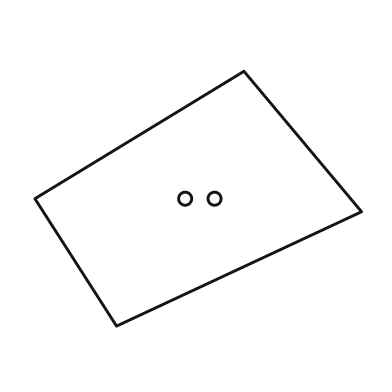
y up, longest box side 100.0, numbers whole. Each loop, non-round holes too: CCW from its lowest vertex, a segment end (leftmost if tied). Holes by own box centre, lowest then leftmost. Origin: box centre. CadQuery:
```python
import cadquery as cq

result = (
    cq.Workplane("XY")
    .moveTo(-25.0, -39.0)
    .lineTo(50.0, -4.0)
    .lineTo(14.0, 39.0)
    .lineTo(-50.0, 0.0)
    .close()
    .moveTo(-4.0, 0.0)
    .circle(2.0)
    .moveTo(5.0, 0.0)
    .circle(2.0)
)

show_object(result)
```